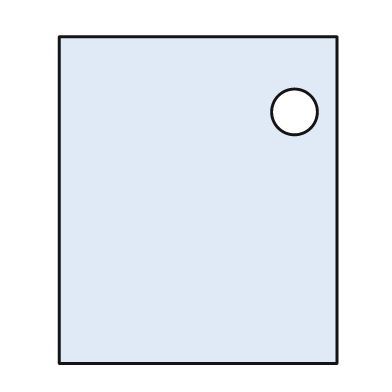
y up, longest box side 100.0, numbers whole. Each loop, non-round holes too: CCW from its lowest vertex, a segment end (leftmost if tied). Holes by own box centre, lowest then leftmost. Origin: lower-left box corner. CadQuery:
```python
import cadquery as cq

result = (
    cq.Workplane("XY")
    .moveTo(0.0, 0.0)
    .lineTo(85.0, 0.0)
    .lineTo(85.0, 100.0)
    .lineTo(0.0, 100.0)
    .close()
    .moveTo(72.0, 77.0)
    .circle(7.0)
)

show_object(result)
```